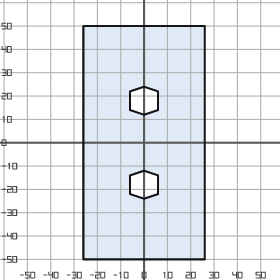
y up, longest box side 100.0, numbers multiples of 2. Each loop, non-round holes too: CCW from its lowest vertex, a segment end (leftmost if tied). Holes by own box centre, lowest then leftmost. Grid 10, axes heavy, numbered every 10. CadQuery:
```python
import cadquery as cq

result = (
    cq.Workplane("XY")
    .moveTo(-26.0, -50.0)
    .lineTo(26.0, -50.0)
    .lineTo(26.0, 50.0)
    .lineTo(-26.0, 50.0)
    .close()
    .moveTo(0.0, -24.0)
    .lineTo(6.0, -22.0)
    .lineTo(6.0, -14.0)
    .lineTo(0.0, -12.0)
    .lineTo(-6.0, -14.0)
    .lineTo(-6.0, -22.0)
    .close()
    .moveTo(0.0, 12.0)
    .lineTo(6.0, 14.0)
    .lineTo(6.0, 22.0)
    .lineTo(0.0, 24.0)
    .lineTo(-6.0, 22.0)
    .lineTo(-6.0, 14.0)
    .close()
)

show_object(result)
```